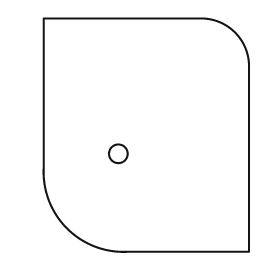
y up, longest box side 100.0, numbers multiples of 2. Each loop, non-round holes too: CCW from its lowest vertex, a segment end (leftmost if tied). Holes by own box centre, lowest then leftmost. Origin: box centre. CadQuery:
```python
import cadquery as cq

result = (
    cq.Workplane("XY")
    .moveTo(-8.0, -50.0)
    .lineTo(44.0, -50.0)
    .lineTo(44.0, 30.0)
    .threePointArc((38.0, 44.0), (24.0, 50.0))
    .lineTo(-44.0, 50.0)
    .lineTo(-44.0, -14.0)
    .threePointArc((-34.0, -40.0), (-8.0, -50.0))
    .close()
    .moveTo(-12.0, -8.0)
    .circle(4.0)
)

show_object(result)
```